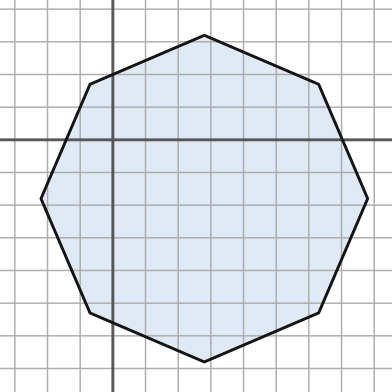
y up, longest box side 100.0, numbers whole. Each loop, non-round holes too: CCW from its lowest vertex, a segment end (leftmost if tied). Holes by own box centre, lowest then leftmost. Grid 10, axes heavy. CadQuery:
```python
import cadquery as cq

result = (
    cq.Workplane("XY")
    .moveTo(28.0, -68.0)
    .lineTo(63.0, -53.0)
    .lineTo(78.0, -18.0)
    .lineTo(63.0, 17.0)
    .lineTo(28.0, 32.0)
    .lineTo(-7.0, 17.0)
    .lineTo(-22.0, -18.0)
    .lineTo(-7.0, -53.0)
    .close()
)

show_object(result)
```